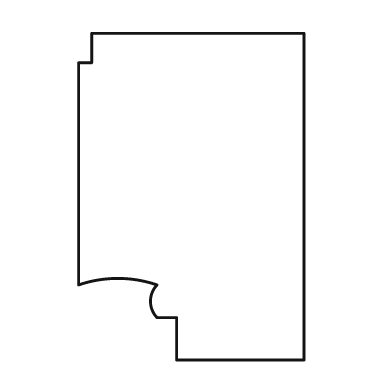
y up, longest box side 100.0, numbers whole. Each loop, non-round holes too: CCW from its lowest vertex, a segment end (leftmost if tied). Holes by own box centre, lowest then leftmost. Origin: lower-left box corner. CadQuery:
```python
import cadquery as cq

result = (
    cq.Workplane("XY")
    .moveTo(30.0, 0.0)
    .lineTo(69.0, 0.0)
    .lineTo(69.0, 100.0)
    .lineTo(4.0, 100.0)
    .lineTo(4.0, 91.0)
    .lineTo(0.0, 91.0)
    .lineTo(0.0, 23.0)
    .threePointArc((12.0, 25.0), (24.0, 23.0))
    .threePointArc((22.0, 18.0), (24.0, 13.0))
    .lineTo(30.0, 13.0)
    .close()
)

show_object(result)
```